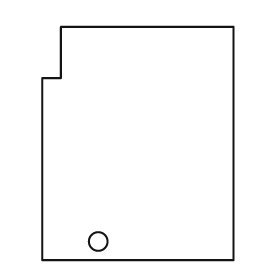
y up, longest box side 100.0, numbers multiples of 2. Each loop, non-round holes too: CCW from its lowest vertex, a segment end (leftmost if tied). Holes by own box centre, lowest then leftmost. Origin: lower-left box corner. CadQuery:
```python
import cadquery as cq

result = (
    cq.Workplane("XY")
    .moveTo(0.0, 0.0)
    .lineTo(82.0, 0.0)
    .lineTo(82.0, 100.0)
    .lineTo(8.0, 100.0)
    .lineTo(8.0, 78.0)
    .lineTo(0.0, 78.0)
    .close()
    .moveTo(24.0, 8.0)
    .circle(4.0)
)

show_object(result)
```